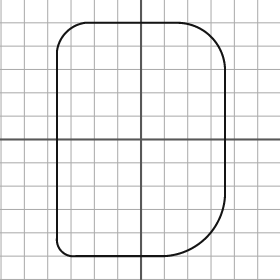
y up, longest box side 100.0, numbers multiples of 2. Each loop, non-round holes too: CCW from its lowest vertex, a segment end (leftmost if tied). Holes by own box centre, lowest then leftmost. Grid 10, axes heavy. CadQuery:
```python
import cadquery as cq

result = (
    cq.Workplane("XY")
    .moveTo(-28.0, -50.0)
    .lineTo(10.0, -50.0)
    .threePointArc((28.0, -42.0), (36.0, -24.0))
    .lineTo(36.0, 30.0)
    .threePointArc((30.0, 44.0), (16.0, 50.0))
    .lineTo(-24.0, 50.0)
    .threePointArc((-32.0, 46.0), (-36.0, 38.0))
    .lineTo(-36.0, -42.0)
    .threePointArc((-34.0, -48.0), (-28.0, -50.0))
    .close()
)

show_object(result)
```